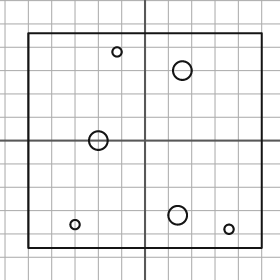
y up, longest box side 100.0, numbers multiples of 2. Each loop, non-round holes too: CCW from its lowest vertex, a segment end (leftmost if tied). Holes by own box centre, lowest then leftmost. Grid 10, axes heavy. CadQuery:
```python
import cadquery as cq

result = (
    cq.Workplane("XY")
    .moveTo(-50.0, -46.0)
    .lineTo(50.0, -46.0)
    .lineTo(50.0, 46.0)
    .lineTo(-50.0, 46.0)
    .close()
    .moveTo(36.0, -38.0)
    .circle(2.0)
    .moveTo(-30.0, -36.0)
    .circle(2.0)
    .moveTo(14.0, -32.0)
    .circle(4.0)
    .moveTo(-20.0, 0.0)
    .circle(4.0)
    .moveTo(16.0, 30.0)
    .circle(4.0)
    .moveTo(-12.0, 38.0)
    .circle(2.0)
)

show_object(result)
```